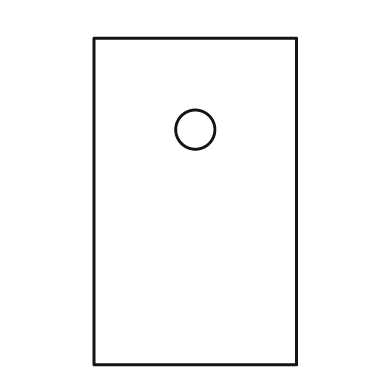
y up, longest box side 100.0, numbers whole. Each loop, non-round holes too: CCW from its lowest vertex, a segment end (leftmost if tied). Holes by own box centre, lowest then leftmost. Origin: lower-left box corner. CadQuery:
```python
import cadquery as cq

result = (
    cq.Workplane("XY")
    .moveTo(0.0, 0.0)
    .lineTo(62.0, 0.0)
    .lineTo(62.0, 100.0)
    .lineTo(0.0, 100.0)
    .close()
    .moveTo(31.0, 72.0)
    .circle(6.0)
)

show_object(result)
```